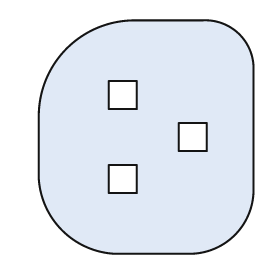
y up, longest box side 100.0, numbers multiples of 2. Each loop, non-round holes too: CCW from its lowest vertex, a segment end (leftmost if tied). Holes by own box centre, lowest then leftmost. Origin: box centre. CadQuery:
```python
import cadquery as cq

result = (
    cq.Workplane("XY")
    .moveTo(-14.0, -50.0)
    .lineTo(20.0, -50.0)
    .threePointArc((38.0, -42.0), (46.0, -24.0))
    .lineTo(46.0, 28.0)
    .threePointArc((40.0, 44.0), (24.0, 50.0))
    .lineTo(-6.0, 50.0)
    .threePointArc((-34.0, 38.0), (-46.0, 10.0))
    .lineTo(-46.0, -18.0)
    .threePointArc((-36.0, -40.0), (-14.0, -50.0))
    .close()
    .moveTo(-16.0, -24.0)
    .lineTo(-4.0, -24.0)
    .lineTo(-4.0, -12.0)
    .lineTo(-16.0, -12.0)
    .close()
    .moveTo(14.0, -6.0)
    .lineTo(26.0, -6.0)
    .lineTo(26.0, 6.0)
    .lineTo(14.0, 6.0)
    .close()
    .moveTo(-16.0, 12.0)
    .lineTo(-4.0, 12.0)
    .lineTo(-4.0, 24.0)
    .lineTo(-16.0, 24.0)
    .close()
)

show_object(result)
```